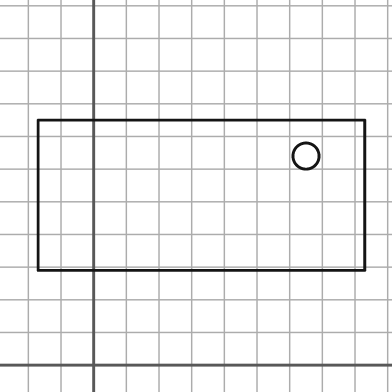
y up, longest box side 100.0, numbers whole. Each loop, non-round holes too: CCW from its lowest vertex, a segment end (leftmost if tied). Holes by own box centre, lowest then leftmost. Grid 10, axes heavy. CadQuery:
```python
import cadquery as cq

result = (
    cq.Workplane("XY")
    .moveTo(-17.0, 29.0)
    .lineTo(83.0, 29.0)
    .lineTo(83.0, 75.0)
    .lineTo(-17.0, 75.0)
    .close()
    .moveTo(65.0, 64.0)
    .circle(4.0)
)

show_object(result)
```